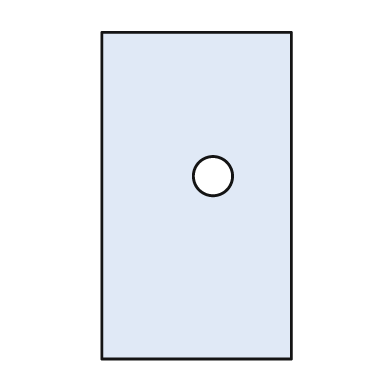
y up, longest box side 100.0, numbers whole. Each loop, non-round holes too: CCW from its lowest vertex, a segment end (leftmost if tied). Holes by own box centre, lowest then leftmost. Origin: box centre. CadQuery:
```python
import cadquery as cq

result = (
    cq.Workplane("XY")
    .moveTo(-29.0, -50.0)
    .lineTo(29.0, -50.0)
    .lineTo(29.0, 50.0)
    .lineTo(-29.0, 50.0)
    .close()
    .moveTo(5.0, 6.0)
    .circle(6.0)
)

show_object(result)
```